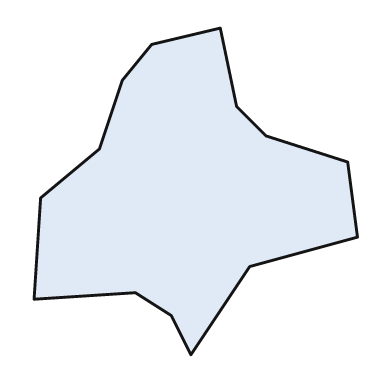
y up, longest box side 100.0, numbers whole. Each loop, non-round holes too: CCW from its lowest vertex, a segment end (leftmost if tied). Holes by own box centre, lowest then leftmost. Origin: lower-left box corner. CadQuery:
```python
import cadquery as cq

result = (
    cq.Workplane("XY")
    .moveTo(48.0, 0.0)
    .lineTo(66.0, 27.0)
    .lineTo(99.0, 36.0)
    .lineTo(96.0, 59.0)
    .lineTo(71.0, 67.0)
    .lineTo(62.0, 76.0)
    .lineTo(57.0, 100.0)
    .lineTo(36.0, 95.0)
    .lineTo(27.0, 84.0)
    .lineTo(20.0, 63.0)
    .lineTo(2.0, 48.0)
    .lineTo(0.0, 17.0)
    .lineTo(31.0, 19.0)
    .lineTo(42.0, 12.0)
    .close()
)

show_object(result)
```